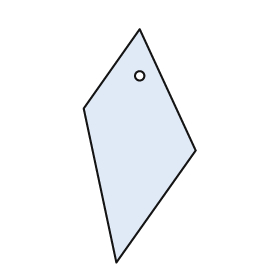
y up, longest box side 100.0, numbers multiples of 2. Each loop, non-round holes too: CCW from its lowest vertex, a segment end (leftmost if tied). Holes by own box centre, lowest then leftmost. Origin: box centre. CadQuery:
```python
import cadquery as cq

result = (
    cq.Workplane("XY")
    .moveTo(-10.0, -50.0)
    .lineTo(24.0, -2.0)
    .lineTo(0.0, 50.0)
    .lineTo(-24.0, 16.0)
    .close()
    .moveTo(0.0, 30.0)
    .circle(2.0)
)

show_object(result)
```